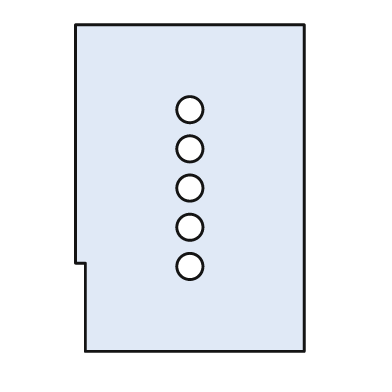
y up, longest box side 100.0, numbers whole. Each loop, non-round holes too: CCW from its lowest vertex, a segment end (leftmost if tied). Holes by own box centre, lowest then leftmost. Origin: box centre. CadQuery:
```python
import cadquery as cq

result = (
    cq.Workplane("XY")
    .moveTo(-32.0, -50.0)
    .lineTo(35.0, -50.0)
    .lineTo(35.0, 50.0)
    .lineTo(-35.0, 50.0)
    .lineTo(-35.0, -23.0)
    .lineTo(-32.0, -23.0)
    .close()
    .moveTo(0.0, -24.0)
    .circle(4.0)
    .moveTo(0.0, -12.0)
    .circle(4.0)
    .moveTo(0.0, 0.0)
    .circle(4.0)
    .moveTo(0.0, 12.0)
    .circle(4.0)
    .moveTo(0.0, 24.0)
    .circle(4.0)
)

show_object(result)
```